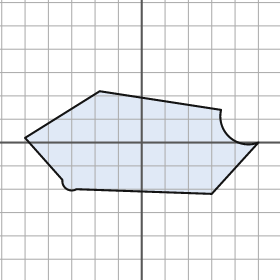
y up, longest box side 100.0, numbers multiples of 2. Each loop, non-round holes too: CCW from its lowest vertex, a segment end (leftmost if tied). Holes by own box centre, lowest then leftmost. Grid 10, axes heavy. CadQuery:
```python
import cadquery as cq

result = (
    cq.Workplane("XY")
    .moveTo(30.0, -22.0)
    .lineTo(50.0, 0.0)
    .threePointArc((38.0, 2.0), (34.0, 14.0))
    .lineTo(-18.0, 22.0)
    .lineTo(-50.0, 2.0)
    .lineTo(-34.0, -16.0)
    .threePointArc((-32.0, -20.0), (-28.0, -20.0))
    .close()
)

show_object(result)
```